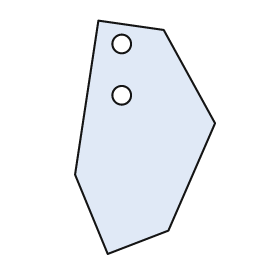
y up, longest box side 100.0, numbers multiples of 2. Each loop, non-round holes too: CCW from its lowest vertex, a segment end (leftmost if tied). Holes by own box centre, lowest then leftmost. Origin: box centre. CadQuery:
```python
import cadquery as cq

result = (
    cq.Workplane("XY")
    .moveTo(-16.0, -50.0)
    .lineTo(10.0, -40.0)
    .lineTo(30.0, 6.0)
    .lineTo(8.0, 46.0)
    .lineTo(-20.0, 50.0)
    .lineTo(-30.0, -16.0)
    .close()
    .moveTo(-10.0, 18.0)
    .circle(4.0)
    .moveTo(-10.0, 40.0)
    .circle(4.0)
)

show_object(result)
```